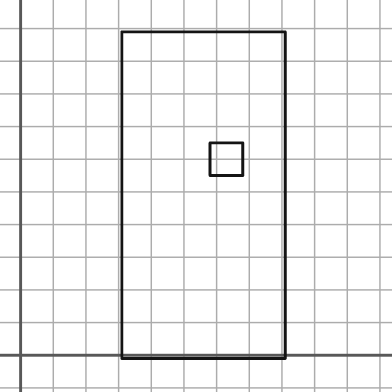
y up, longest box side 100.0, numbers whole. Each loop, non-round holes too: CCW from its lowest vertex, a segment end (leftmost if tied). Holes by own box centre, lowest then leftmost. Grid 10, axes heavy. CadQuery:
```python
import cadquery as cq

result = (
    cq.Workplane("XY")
    .moveTo(31.0, -1.0)
    .lineTo(81.0, -1.0)
    .lineTo(81.0, 99.0)
    .lineTo(31.0, 99.0)
    .close()
    .moveTo(58.0, 55.0)
    .lineTo(68.0, 55.0)
    .lineTo(68.0, 65.0)
    .lineTo(58.0, 65.0)
    .close()
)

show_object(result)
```